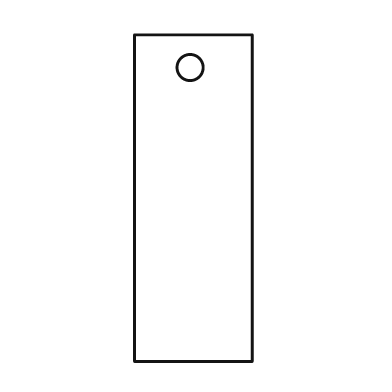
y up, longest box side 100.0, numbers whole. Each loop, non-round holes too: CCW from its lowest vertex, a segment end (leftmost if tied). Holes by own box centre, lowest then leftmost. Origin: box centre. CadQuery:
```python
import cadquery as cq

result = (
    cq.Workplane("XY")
    .moveTo(-18.0, -50.0)
    .lineTo(18.0, -50.0)
    .lineTo(18.0, 50.0)
    .lineTo(-18.0, 50.0)
    .close()
    .moveTo(-1.0, 40.0)
    .circle(4.0)
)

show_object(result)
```